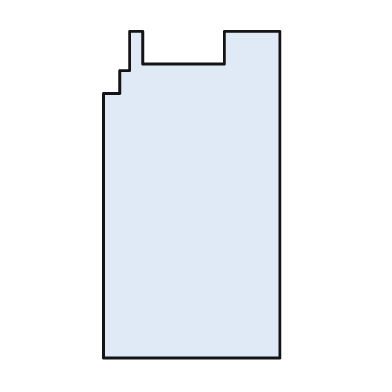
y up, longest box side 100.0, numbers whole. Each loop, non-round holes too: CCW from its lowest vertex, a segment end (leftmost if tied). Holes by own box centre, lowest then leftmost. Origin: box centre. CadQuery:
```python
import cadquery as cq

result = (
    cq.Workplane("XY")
    .moveTo(-27.0, -50.0)
    .lineTo(27.0, -50.0)
    .lineTo(27.0, 50.0)
    .lineTo(10.0, 50.0)
    .lineTo(10.0, 40.0)
    .lineTo(-15.0, 40.0)
    .lineTo(-15.0, 50.0)
    .lineTo(-19.0, 50.0)
    .lineTo(-19.0, 38.0)
    .lineTo(-22.0, 38.0)
    .lineTo(-22.0, 31.0)
    .lineTo(-27.0, 31.0)
    .close()
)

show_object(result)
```